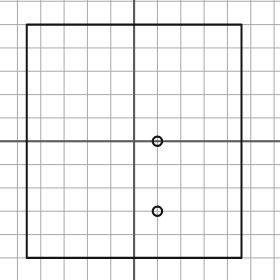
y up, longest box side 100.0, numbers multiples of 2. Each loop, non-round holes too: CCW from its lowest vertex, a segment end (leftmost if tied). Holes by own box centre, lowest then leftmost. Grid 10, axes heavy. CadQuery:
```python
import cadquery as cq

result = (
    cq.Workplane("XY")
    .moveTo(-46.0, -50.0)
    .lineTo(46.0, -50.0)
    .lineTo(46.0, 50.0)
    .lineTo(-46.0, 50.0)
    .close()
    .moveTo(10.0, -30.0)
    .circle(2.0)
    .moveTo(10.0, 0.0)
    .circle(2.0)
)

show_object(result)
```